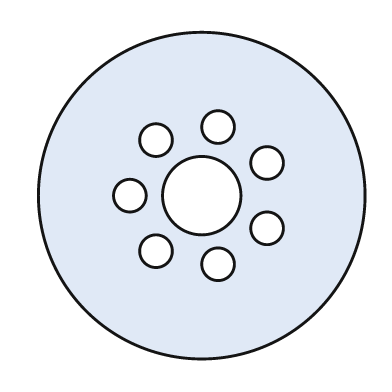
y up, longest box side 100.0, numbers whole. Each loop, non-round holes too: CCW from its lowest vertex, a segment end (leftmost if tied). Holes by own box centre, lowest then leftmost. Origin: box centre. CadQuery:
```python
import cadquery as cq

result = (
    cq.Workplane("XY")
    .moveTo(0.0, 0.0)
    .circle(50.0)
    .moveTo(5.0, -21.0)
    .circle(5.0)
    .moveTo(-14.0, -17.0)
    .circle(5.0)
    .moveTo(20.0, -10.0)
    .circle(5.0)
    .moveTo(-22.0, 0.0)
    .circle(5.0)
    .moveTo(0.0, 0.0)
    .circle(12.0)
    .moveTo(20.0, 10.0)
    .circle(5.0)
    .moveTo(-14.0, 17.0)
    .circle(5.0)
    .moveTo(5.0, 21.0)
    .circle(5.0)
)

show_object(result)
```